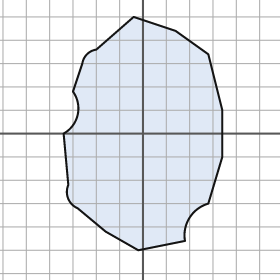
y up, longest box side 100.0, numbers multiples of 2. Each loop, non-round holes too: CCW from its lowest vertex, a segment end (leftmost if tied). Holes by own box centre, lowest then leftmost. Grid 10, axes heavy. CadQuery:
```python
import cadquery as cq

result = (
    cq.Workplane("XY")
    .moveTo(-2.0, -50.0)
    .lineTo(18.0, -46.0)
    .threePointArc((20.0, -36.0), (28.0, -30.0))
    .lineTo(34.0, -10.0)
    .lineTo(34.0, 10.0)
    .lineTo(28.0, 34.0)
    .lineTo(14.0, 44.0)
    .lineTo(-4.0, 50.0)
    .lineTo(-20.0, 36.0)
    .threePointArc((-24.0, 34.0), (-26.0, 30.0))
    .lineTo(-30.0, 18.0)
    .threePointArc((-28.0, 8.0), (-34.0, 0.0))
    .lineTo(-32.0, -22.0)
    .threePointArc((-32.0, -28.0), (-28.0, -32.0))
    .lineTo(-16.0, -42.0)
    .close()
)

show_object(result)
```